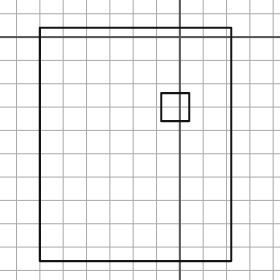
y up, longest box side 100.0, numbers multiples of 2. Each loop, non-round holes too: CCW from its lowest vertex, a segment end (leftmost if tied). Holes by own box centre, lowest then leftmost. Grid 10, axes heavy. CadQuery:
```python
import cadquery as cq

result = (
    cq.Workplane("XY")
    .moveTo(-60.0, -96.0)
    .lineTo(22.0, -96.0)
    .lineTo(22.0, 4.0)
    .lineTo(-60.0, 4.0)
    .close()
    .moveTo(-8.0, -36.0)
    .lineTo(4.0, -36.0)
    .lineTo(4.0, -24.0)
    .lineTo(-8.0, -24.0)
    .close()
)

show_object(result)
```